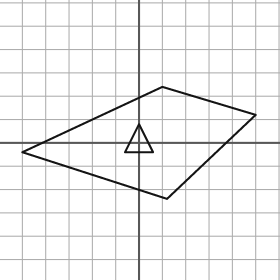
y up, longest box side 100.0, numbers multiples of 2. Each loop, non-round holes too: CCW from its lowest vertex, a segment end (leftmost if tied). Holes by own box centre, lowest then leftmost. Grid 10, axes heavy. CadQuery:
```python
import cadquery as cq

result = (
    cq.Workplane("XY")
    .moveTo(12.0, -24.0)
    .lineTo(50.0, 12.0)
    .lineTo(10.0, 24.0)
    .lineTo(-50.0, -4.0)
    .close()
    .moveTo(-6.0, -4.0)
    .lineTo(6.0, -4.0)
    .lineTo(0.0, 8.0)
    .close()
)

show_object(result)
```